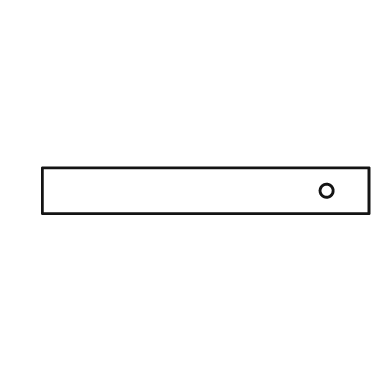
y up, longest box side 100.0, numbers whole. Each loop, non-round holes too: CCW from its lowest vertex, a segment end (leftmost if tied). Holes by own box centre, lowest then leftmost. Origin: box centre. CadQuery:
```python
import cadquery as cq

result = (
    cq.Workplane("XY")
    .moveTo(-50.0, -7.0)
    .lineTo(50.0, -7.0)
    .lineTo(50.0, 7.0)
    .lineTo(-50.0, 7.0)
    .close()
    .moveTo(37.0, 0.0)
    .circle(2.0)
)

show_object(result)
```